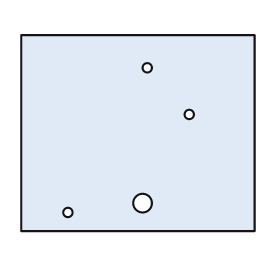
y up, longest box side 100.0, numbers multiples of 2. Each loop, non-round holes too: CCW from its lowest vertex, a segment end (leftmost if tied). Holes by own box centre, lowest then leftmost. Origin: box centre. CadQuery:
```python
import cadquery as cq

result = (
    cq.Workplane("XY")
    .moveTo(-50.0, -42.0)
    .lineTo(50.0, -42.0)
    .lineTo(50.0, 42.0)
    .lineTo(-50.0, 42.0)
    .close()
    .moveTo(-30.0, -34.0)
    .circle(2.0)
    .moveTo(2.0, -30.0)
    .circle(4.0)
    .moveTo(22.0, 8.0)
    .circle(2.0)
    .moveTo(4.0, 28.0)
    .circle(2.0)
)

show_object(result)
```